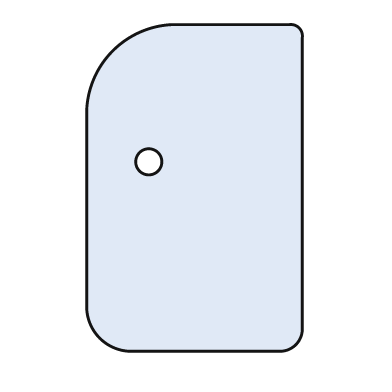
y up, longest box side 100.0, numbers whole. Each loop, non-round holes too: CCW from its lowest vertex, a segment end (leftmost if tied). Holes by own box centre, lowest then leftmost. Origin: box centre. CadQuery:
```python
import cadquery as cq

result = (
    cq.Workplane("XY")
    .moveTo(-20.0, -50.0)
    .lineTo(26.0, -50.0)
    .threePointArc((31.0, -48.0), (33.0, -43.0))
    .lineTo(33.0, 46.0)
    .threePointArc((32.0, 49.0), (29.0, 50.0))
    .lineTo(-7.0, 50.0)
    .threePointArc((-25.0, 42.0), (-33.0, 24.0))
    .lineTo(-33.0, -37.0)
    .threePointArc((-29.0, -46.0), (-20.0, -50.0))
    .close()
    .moveTo(-14.0, 8.0)
    .circle(4.0)
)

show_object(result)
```